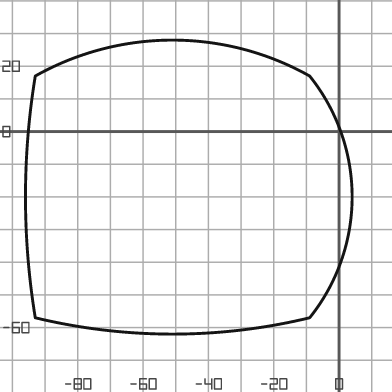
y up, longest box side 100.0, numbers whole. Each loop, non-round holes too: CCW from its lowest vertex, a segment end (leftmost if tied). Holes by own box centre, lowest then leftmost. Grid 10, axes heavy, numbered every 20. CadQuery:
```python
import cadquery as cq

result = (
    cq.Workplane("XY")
    .moveTo(-93.0, -57.0)
    .threePointArc((-51.0, -62.0), (-9.0, -57.0))
    .threePointArc((4.0, -20.0), (-9.0, 17.0))
    .threePointArc((-51.0, 28.0), (-93.0, 17.0))
    .threePointArc((-96.0, -20.0), (-93.0, -57.0))
    .close()
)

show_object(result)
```